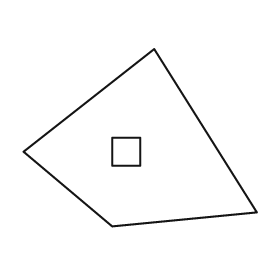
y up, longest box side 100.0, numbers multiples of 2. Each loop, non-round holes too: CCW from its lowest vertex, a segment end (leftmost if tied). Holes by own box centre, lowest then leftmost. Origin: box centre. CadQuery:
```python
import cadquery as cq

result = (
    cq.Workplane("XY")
    .moveTo(-12.0, -38.0)
    .lineTo(50.0, -32.0)
    .lineTo(6.0, 38.0)
    .lineTo(-50.0, -6.0)
    .close()
    .moveTo(-12.0, -12.0)
    .lineTo(0.0, -12.0)
    .lineTo(0.0, 0.0)
    .lineTo(-12.0, 0.0)
    .close()
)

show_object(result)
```